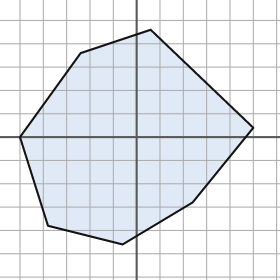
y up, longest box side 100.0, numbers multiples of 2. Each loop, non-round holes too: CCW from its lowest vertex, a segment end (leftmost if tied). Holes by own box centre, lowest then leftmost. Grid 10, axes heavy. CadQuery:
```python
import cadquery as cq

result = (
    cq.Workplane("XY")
    .moveTo(-6.0, -46.0)
    .lineTo(24.0, -28.0)
    .lineTo(50.0, 4.0)
    .lineTo(6.0, 46.0)
    .lineTo(-24.0, 36.0)
    .lineTo(-50.0, 0.0)
    .lineTo(-38.0, -38.0)
    .close()
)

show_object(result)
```